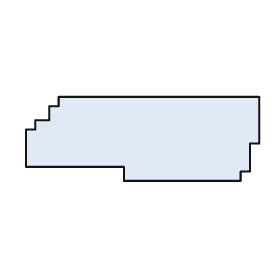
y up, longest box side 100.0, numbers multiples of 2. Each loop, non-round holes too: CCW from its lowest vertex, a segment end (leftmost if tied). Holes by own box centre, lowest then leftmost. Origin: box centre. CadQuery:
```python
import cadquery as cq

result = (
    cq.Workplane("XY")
    .moveTo(-8.0, -18.0)
    .lineTo(42.0, -18.0)
    .lineTo(42.0, -14.0)
    .lineTo(46.0, -14.0)
    .lineTo(46.0, -2.0)
    .lineTo(50.0, -2.0)
    .lineTo(50.0, 18.0)
    .lineTo(-36.0, 18.0)
    .lineTo(-36.0, 14.0)
    .lineTo(-40.0, 14.0)
    .lineTo(-40.0, 8.0)
    .lineTo(-46.0, 8.0)
    .lineTo(-46.0, 4.0)
    .lineTo(-50.0, 4.0)
    .lineTo(-50.0, -12.0)
    .lineTo(-8.0, -12.0)
    .close()
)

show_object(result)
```